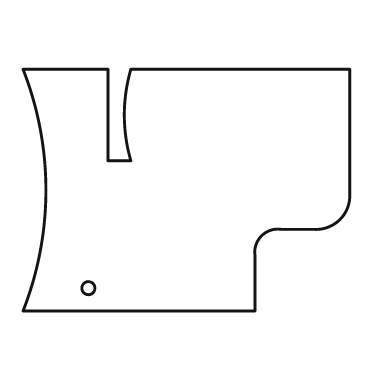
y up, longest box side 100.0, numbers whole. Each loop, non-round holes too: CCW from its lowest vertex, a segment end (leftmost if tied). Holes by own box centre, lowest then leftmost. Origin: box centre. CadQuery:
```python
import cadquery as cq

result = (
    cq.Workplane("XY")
    .moveTo(-50.0, -37.0)
    .lineTo(21.0, -37.0)
    .lineTo(21.0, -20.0)
    .threePointArc((23.0, -14.0), (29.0, -12.0))
    .lineTo(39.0, -12.0)
    .threePointArc((47.0, -9.0), (50.0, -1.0))
    .lineTo(50.0, 37.0)
    .lineTo(-17.0, 37.0)
    .threePointArc((-19.0, 23.0), (-17.0, 9.0))
    .lineTo(-24.0, 9.0)
    .lineTo(-24.0, 37.0)
    .lineTo(-50.0, 37.0)
    .threePointArc((-43.0, 0.0), (-50.0, -37.0))
    .close()
    .moveTo(-30.0, -30.0)
    .circle(2.0)
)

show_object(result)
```